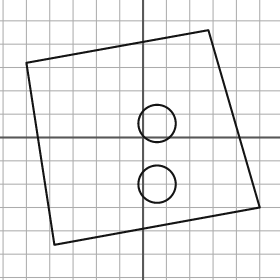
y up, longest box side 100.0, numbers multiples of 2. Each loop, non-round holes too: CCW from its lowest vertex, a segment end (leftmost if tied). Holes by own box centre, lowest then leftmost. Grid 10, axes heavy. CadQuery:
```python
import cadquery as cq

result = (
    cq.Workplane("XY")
    .moveTo(-38.0, -46.0)
    .lineTo(50.0, -30.0)
    .lineTo(28.0, 46.0)
    .lineTo(-50.0, 32.0)
    .close()
    .moveTo(6.0, -20.0)
    .circle(8.0)
    .moveTo(6.0, 6.0)
    .circle(8.0)
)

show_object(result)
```